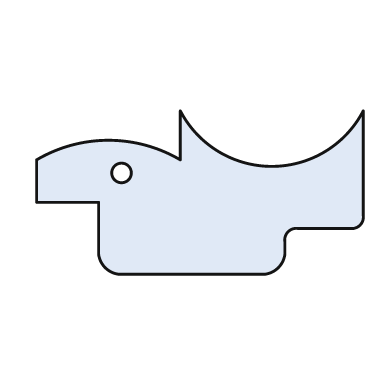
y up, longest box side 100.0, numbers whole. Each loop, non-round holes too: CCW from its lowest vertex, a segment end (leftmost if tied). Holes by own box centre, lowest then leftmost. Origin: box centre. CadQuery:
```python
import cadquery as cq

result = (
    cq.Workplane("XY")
    .moveTo(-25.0, -25.0)
    .lineTo(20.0, -25.0)
    .threePointArc((24.0, -23.0), (26.0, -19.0))
    .lineTo(26.0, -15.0)
    .threePointArc((27.0, -12.0), (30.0, -11.0))
    .lineTo(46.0, -11.0)
    .threePointArc((49.0, -10.0), (50.0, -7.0))
    .lineTo(50.0, 25.0)
    .threePointArc((22.0, 8.0), (-6.0, 25.0))
    .lineTo(-6.0, 10.0)
    .threePointArc((-28.0, 16.0), (-50.0, 10.0))
    .lineTo(-50.0, -3.0)
    .lineTo(-31.0, -3.0)
    .lineTo(-31.0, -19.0)
    .threePointArc((-29.0, -23.0), (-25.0, -25.0))
    .close()
    .moveTo(-24.0, 6.0)
    .circle(3.0)
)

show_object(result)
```